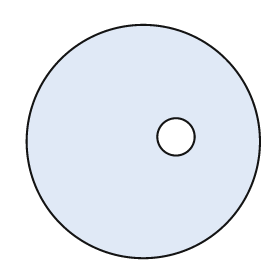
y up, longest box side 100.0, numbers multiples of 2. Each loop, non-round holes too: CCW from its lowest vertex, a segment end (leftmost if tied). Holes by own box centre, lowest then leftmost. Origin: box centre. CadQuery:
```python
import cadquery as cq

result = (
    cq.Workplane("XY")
    .moveTo(0.0, 0.0)
    .circle(50.0)
    .moveTo(14.0, 2.0)
    .circle(8.0)
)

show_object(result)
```